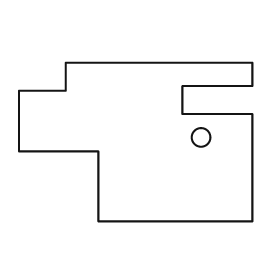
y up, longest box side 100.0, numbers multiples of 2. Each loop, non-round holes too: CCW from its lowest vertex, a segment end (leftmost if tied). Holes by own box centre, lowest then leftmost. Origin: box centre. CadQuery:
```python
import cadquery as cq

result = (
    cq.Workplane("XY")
    .moveTo(-16.0, -34.0)
    .lineTo(50.0, -34.0)
    .lineTo(50.0, 12.0)
    .lineTo(20.0, 12.0)
    .lineTo(20.0, 24.0)
    .lineTo(50.0, 24.0)
    .lineTo(50.0, 34.0)
    .lineTo(-30.0, 34.0)
    .lineTo(-30.0, 22.0)
    .lineTo(-50.0, 22.0)
    .lineTo(-50.0, -4.0)
    .lineTo(-16.0, -4.0)
    .close()
    .moveTo(28.0, 2.0)
    .circle(4.0)
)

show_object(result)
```